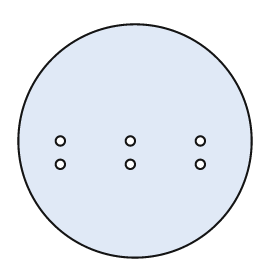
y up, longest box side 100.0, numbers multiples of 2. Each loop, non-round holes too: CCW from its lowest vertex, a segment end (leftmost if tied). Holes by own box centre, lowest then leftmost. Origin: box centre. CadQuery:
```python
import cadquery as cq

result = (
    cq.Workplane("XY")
    .moveTo(0.0, 0.0)
    .circle(50.0)
    .moveTo(-32.0, -10.0)
    .circle(2.0)
    .moveTo(-2.0, -10.0)
    .circle(2.0)
    .moveTo(28.0, -10.0)
    .circle(2.0)
    .moveTo(-32.0, 0.0)
    .circle(2.0)
    .moveTo(-2.0, 0.0)
    .circle(2.0)
    .moveTo(28.0, 0.0)
    .circle(2.0)
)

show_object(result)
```